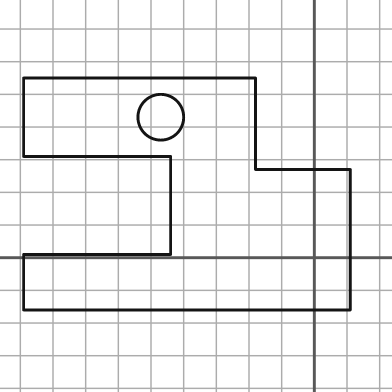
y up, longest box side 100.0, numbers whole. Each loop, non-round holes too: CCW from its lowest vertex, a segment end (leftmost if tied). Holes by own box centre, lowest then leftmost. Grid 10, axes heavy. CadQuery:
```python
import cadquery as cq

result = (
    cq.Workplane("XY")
    .moveTo(-89.0, -16.0)
    .lineTo(11.0, -16.0)
    .lineTo(11.0, 27.0)
    .lineTo(-18.0, 27.0)
    .lineTo(-18.0, 55.0)
    .lineTo(-89.0, 55.0)
    .lineTo(-89.0, 31.0)
    .lineTo(-44.0, 31.0)
    .lineTo(-44.0, 1.0)
    .lineTo(-89.0, 1.0)
    .close()
    .moveTo(-47.0, 43.0)
    .circle(7.0)
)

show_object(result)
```